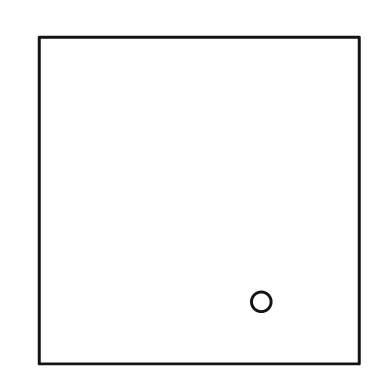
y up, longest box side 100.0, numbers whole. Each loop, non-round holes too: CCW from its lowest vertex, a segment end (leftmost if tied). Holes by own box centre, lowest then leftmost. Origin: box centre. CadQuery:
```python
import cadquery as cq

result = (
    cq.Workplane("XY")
    .moveTo(-49.0, -50.0)
    .lineTo(49.0, -50.0)
    .lineTo(49.0, 50.0)
    .lineTo(-49.0, 50.0)
    .close()
    .moveTo(19.0, -31.0)
    .circle(3.0)
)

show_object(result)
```